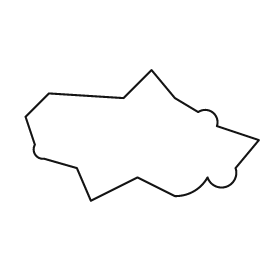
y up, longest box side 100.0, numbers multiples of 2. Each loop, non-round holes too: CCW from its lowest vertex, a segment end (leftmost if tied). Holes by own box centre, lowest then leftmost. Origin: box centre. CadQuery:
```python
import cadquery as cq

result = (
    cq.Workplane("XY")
    .moveTo(-22.0, -28.0)
    .lineTo(-2.0, -18.0)
    .lineTo(14.0, -26.0)
    .threePointArc((22.0, -24.0), (28.0, -18.0))
    .threePointArc((36.0, -22.0), (40.0, -14.0))
    .lineTo(50.0, -2.0)
    .lineTo(32.0, 4.0)
    .threePointArc((30.0, 10.0), (24.0, 10.0))
    .lineTo(14.0, 16.0)
    .lineTo(4.0, 28.0)
    .lineTo(-8.0, 16.0)
    .lineTo(-40.0, 18.0)
    .lineTo(-50.0, 8.0)
    .lineTo(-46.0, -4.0)
    .threePointArc((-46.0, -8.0), (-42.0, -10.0))
    .lineTo(-28.0, -14.0)
    .close()
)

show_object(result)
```